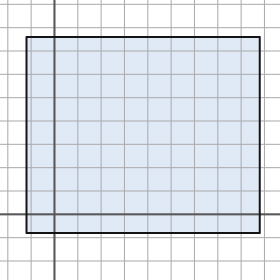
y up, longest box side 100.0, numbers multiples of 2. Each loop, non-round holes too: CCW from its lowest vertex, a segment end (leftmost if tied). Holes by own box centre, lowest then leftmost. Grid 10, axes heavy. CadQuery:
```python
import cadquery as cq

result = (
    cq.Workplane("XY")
    .moveTo(-12.0, -8.0)
    .lineTo(88.0, -8.0)
    .lineTo(88.0, 76.0)
    .lineTo(-12.0, 76.0)
    .close()
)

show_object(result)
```